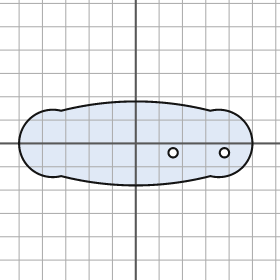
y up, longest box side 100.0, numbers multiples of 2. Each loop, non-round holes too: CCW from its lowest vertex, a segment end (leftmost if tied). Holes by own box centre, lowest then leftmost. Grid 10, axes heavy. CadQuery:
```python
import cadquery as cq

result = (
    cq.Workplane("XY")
    .moveTo(-32.0, -14.0)
    .threePointArc((0.0, -18.0), (32.0, -14.0))
    .threePointArc((50.0, 0.0), (32.0, 14.0))
    .threePointArc((0.0, 18.0), (-32.0, 14.0))
    .threePointArc((-50.0, 0.0), (-32.0, -14.0))
    .close()
    .moveTo(16.0, -4.0)
    .circle(2.0)
    .moveTo(38.0, -4.0)
    .circle(2.0)
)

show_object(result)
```